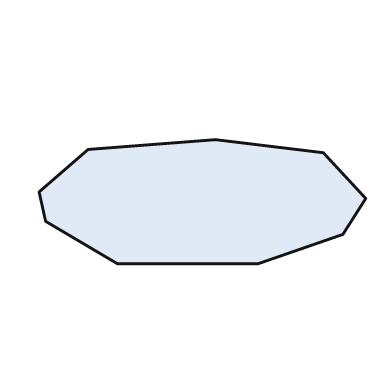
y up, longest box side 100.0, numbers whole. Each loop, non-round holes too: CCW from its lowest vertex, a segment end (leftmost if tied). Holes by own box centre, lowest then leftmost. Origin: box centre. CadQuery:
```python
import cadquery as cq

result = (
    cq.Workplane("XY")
    .moveTo(-26.0, -19.0)
    .lineTo(17.0, -19.0)
    .lineTo(43.0, -10.0)
    .lineTo(50.0, 1.0)
    .lineTo(37.0, 15.0)
    .lineTo(4.0, 19.0)
    .lineTo(-35.0, 16.0)
    .lineTo(-50.0, 3.0)
    .lineTo(-48.0, -6.0)
    .close()
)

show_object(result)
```